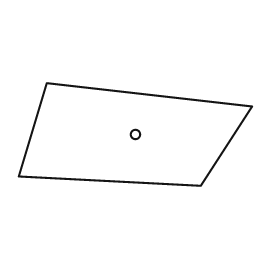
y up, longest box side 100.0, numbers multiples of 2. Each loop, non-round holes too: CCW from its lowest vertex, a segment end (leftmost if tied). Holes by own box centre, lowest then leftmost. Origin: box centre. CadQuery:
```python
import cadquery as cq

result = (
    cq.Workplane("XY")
    .moveTo(28.0, -22.0)
    .lineTo(50.0, 12.0)
    .lineTo(-38.0, 22.0)
    .lineTo(-50.0, -18.0)
    .close()
    .moveTo(0.0, 0.0)
    .circle(2.0)
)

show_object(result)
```